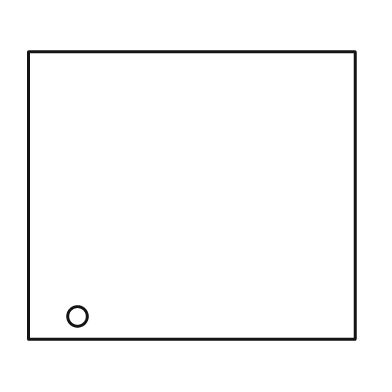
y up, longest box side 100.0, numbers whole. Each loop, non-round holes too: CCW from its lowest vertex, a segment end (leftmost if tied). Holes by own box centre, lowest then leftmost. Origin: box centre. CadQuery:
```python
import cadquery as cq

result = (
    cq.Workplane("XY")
    .moveTo(-50.0, -44.0)
    .lineTo(50.0, -44.0)
    .lineTo(50.0, 44.0)
    .lineTo(-50.0, 44.0)
    .close()
    .moveTo(-35.0, -37.0)
    .circle(3.0)
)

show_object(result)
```